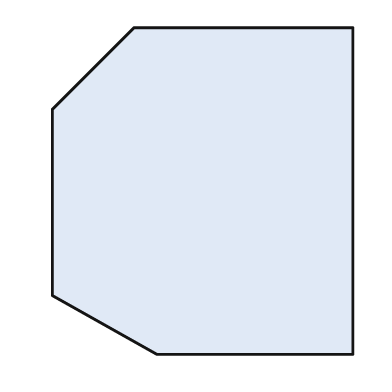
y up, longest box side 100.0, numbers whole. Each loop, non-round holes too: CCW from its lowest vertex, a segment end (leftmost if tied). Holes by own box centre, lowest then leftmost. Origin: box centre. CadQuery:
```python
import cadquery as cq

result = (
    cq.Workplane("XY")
    .moveTo(-14.0, -50.0)
    .lineTo(46.0, -50.0)
    .lineTo(46.0, 50.0)
    .lineTo(-21.0, 50.0)
    .lineTo(-46.0, 25.0)
    .lineTo(-46.0, -32.0)
    .close()
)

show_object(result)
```